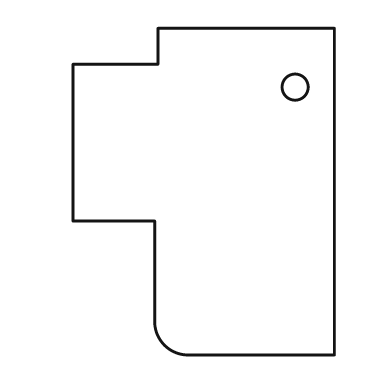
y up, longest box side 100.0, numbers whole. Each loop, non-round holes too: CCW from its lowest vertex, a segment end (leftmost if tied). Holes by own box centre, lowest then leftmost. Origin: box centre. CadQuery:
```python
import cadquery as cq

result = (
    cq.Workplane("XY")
    .moveTo(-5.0, -50.0)
    .lineTo(40.0, -50.0)
    .lineTo(40.0, 50.0)
    .lineTo(-14.0, 50.0)
    .lineTo(-14.0, 39.0)
    .lineTo(-40.0, 39.0)
    .lineTo(-40.0, -9.0)
    .lineTo(-15.0, -9.0)
    .lineTo(-15.0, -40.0)
    .threePointArc((-12.0, -47.0), (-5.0, -50.0))
    .close()
    .moveTo(28.0, 32.0)
    .circle(4.0)
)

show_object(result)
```